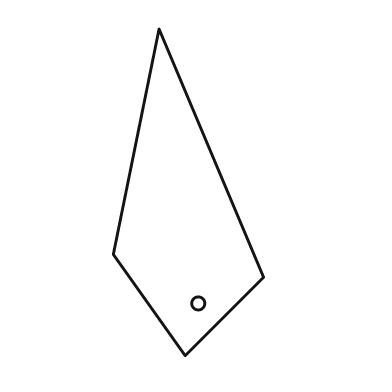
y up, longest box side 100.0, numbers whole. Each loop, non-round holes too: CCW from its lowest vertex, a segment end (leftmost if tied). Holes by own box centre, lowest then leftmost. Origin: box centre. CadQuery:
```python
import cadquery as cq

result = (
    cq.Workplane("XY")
    .moveTo(-1.0, -50.0)
    .lineTo(23.0, -26.0)
    .lineTo(-9.0, 50.0)
    .lineTo(-23.0, -19.0)
    .close()
    .moveTo(3.0, -34.0)
    .circle(2.0)
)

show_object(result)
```